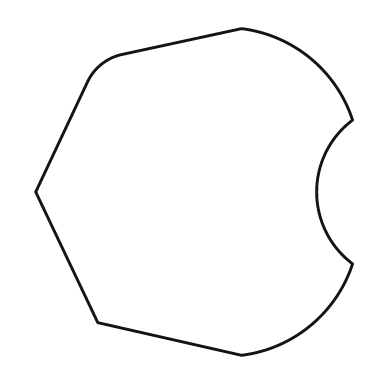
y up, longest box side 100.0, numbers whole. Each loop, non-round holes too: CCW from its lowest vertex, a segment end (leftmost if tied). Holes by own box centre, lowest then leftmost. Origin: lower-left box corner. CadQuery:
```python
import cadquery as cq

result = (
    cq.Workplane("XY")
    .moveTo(63.0, 0.0)
    .threePointArc((84.0, 9.0), (97.0, 28.0))
    .threePointArc((86.0, 50.0), (97.0, 72.0))
    .threePointArc((84.0, 91.0), (63.0, 100.0))
    .lineTo(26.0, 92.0)
    .threePointArc((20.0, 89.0), (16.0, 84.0))
    .lineTo(0.0, 50.0)
    .lineTo(19.0, 10.0)
    .close()
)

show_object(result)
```